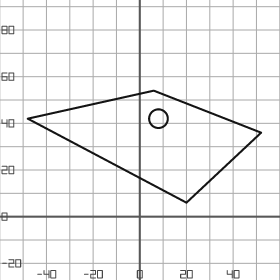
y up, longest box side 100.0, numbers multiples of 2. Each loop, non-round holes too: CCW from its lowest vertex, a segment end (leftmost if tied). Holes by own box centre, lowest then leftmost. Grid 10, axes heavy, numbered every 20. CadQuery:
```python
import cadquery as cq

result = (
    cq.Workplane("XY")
    .moveTo(20.0, 6.0)
    .lineTo(52.0, 36.0)
    .lineTo(6.0, 54.0)
    .lineTo(-48.0, 42.0)
    .close()
    .moveTo(8.0, 42.0)
    .circle(4.0)
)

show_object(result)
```